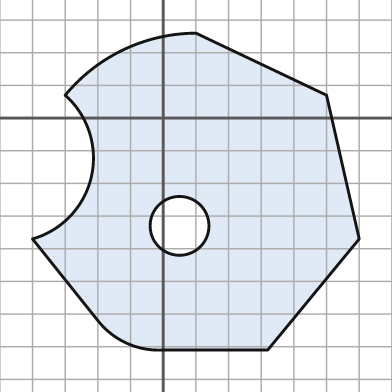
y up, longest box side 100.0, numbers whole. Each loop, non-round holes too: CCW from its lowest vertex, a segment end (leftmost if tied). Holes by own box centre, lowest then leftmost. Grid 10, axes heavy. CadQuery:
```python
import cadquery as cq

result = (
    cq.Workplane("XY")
    .moveTo(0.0, -71.0)
    .lineTo(32.0, -71.0)
    .lineTo(60.0, -37.0)
    .lineTo(50.0, 7.0)
    .lineTo(10.0, 26.0)
    .threePointArc((-12.0, 21.0), (-30.0, 7.0))
    .threePointArc((-22.0, -18.0), (-40.0, -37.0))
    .lineTo(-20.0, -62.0)
    .threePointArc((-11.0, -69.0), (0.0, -71.0))
    .close()
    .moveTo(5.0, -33.0)
    .circle(9.0)
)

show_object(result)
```